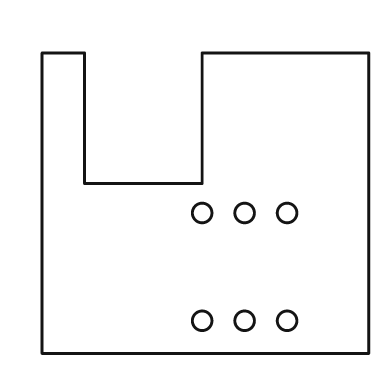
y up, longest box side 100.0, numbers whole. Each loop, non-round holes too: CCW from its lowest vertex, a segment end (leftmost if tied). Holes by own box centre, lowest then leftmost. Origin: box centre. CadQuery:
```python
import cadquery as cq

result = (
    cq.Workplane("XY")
    .moveTo(-50.0, -46.0)
    .lineTo(50.0, -46.0)
    .lineTo(50.0, 46.0)
    .lineTo(-1.0, 46.0)
    .lineTo(-1.0, 6.0)
    .lineTo(-37.0, 6.0)
    .lineTo(-37.0, 46.0)
    .lineTo(-50.0, 46.0)
    .close()
    .moveTo(-1.0, -36.0)
    .circle(3.0)
    .moveTo(12.0, -36.0)
    .circle(3.0)
    .moveTo(25.0, -36.0)
    .circle(3.0)
    .moveTo(-1.0, -3.0)
    .circle(3.0)
    .moveTo(12.0, -3.0)
    .circle(3.0)
    .moveTo(25.0, -3.0)
    .circle(3.0)
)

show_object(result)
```